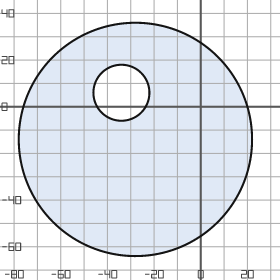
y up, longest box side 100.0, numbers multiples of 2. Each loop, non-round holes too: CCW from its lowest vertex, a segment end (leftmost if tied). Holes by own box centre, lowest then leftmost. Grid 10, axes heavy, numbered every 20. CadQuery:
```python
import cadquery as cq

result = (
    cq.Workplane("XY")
    .moveTo(-28.0, -14.0)
    .circle(50.0)
    .moveTo(-34.0, 6.0)
    .circle(12.0)
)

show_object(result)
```